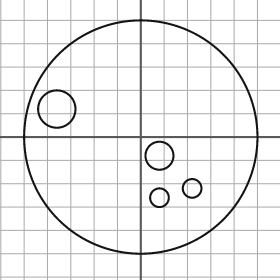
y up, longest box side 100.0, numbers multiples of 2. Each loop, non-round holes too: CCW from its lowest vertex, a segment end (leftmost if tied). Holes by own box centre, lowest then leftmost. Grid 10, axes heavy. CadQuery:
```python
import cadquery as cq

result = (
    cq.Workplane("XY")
    .moveTo(0.0, 0.0)
    .circle(50.0)
    .moveTo(8.0, -26.0)
    .circle(4.0)
    .moveTo(22.0, -22.0)
    .circle(4.0)
    .moveTo(8.0, -8.0)
    .circle(6.0)
    .moveTo(-36.0, 12.0)
    .circle(8.0)
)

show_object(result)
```